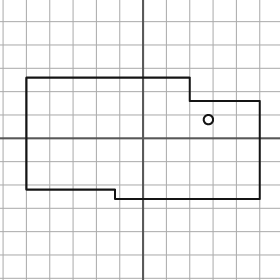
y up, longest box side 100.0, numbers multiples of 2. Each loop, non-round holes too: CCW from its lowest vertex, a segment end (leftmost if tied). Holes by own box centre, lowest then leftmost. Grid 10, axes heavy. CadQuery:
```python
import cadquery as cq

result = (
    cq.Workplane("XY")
    .moveTo(-12.0, -26.0)
    .lineTo(50.0, -26.0)
    .lineTo(50.0, 16.0)
    .lineTo(20.0, 16.0)
    .lineTo(20.0, 26.0)
    .lineTo(-50.0, 26.0)
    .lineTo(-50.0, -22.0)
    .lineTo(-12.0, -22.0)
    .close()
    .moveTo(28.0, 8.0)
    .circle(2.0)
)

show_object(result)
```